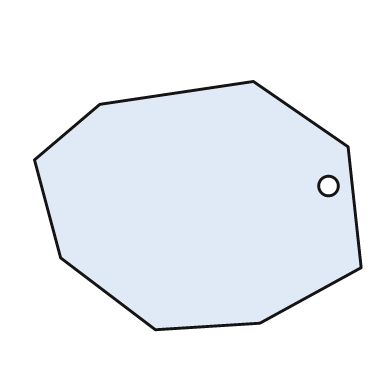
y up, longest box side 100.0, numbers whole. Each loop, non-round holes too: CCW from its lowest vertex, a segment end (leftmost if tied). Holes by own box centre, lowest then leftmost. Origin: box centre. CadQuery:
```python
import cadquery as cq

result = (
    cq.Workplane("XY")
    .moveTo(-13.0, -38.0)
    .lineTo(19.0, -36.0)
    .lineTo(50.0, -19.0)
    .lineTo(46.0, 18.0)
    .lineTo(17.0, 38.0)
    .lineTo(-30.0, 31.0)
    .lineTo(-50.0, 14.0)
    .lineTo(-42.0, -16.0)
    .close()
    .moveTo(40.0, 6.0)
    .circle(3.0)
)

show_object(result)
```